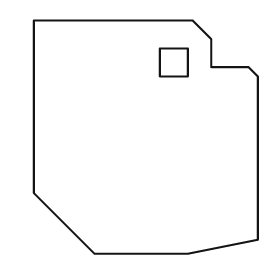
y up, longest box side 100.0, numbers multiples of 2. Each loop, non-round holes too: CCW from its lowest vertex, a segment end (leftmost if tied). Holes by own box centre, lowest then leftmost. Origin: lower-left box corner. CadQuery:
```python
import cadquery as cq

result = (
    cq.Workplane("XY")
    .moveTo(26.0, 0.0)
    .lineTo(66.0, 0.0)
    .lineTo(96.0, 6.0)
    .lineTo(96.0, 76.0)
    .lineTo(92.0, 80.0)
    .lineTo(76.0, 80.0)
    .lineTo(76.0, 92.0)
    .lineTo(68.0, 100.0)
    .lineTo(0.0, 100.0)
    .lineTo(0.0, 26.0)
    .close()
    .moveTo(54.0, 76.0)
    .lineTo(66.0, 76.0)
    .lineTo(66.0, 88.0)
    .lineTo(54.0, 88.0)
    .close()
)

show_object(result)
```